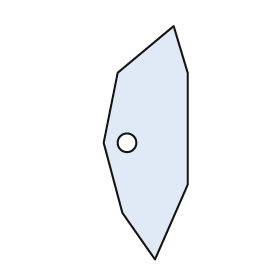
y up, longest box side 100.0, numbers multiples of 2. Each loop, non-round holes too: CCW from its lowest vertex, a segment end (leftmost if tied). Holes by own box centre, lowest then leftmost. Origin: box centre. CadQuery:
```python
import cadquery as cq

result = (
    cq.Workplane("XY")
    .moveTo(4.0, -50.0)
    .lineTo(18.0, -18.0)
    .lineTo(18.0, 30.0)
    .lineTo(12.0, 50.0)
    .lineTo(-12.0, 30.0)
    .lineTo(-18.0, 0.0)
    .lineTo(-10.0, -30.0)
    .close()
    .moveTo(-8.0, 0.0)
    .circle(4.0)
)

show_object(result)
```